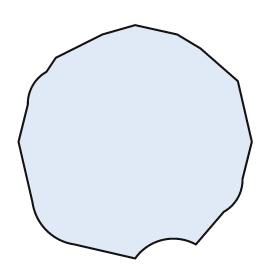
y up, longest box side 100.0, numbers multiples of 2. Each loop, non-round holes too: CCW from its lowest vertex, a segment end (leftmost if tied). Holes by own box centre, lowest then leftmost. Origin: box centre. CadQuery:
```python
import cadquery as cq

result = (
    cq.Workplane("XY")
    .moveTo(0.0, -50.0)
    .threePointArc((12.0, -42.0), (26.0, -44.0))
    .lineTo(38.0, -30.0)
    .threePointArc((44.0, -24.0), (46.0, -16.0))
    .lineTo(50.0, 0.0)
    .lineTo(44.0, 26.0)
    .lineTo(28.0, 40.0)
    .lineTo(18.0, 46.0)
    .lineTo(0.0, 50.0)
    .lineTo(-14.0, 46.0)
    .lineTo(-34.0, 36.0)
    .lineTo(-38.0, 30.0)
    .threePointArc((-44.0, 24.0), (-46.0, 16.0))
    .lineTo(-50.0, 0.0)
    .lineTo(-44.0, -26.0)
    .threePointArc((-38.0, -38.0), (-26.0, -44.0))
    .close()
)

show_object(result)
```